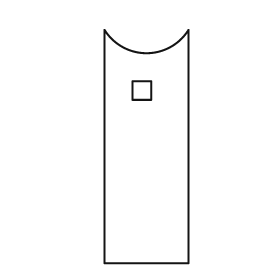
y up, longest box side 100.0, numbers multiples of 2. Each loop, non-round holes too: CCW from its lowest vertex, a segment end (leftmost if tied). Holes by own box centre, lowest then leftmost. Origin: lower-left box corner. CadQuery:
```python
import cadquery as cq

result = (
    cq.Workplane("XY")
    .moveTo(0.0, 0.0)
    .lineTo(36.0, 0.0)
    .lineTo(36.0, 100.0)
    .threePointArc((18.0, 90.0), (0.0, 100.0))
    .close()
    .moveTo(12.0, 70.0)
    .lineTo(20.0, 70.0)
    .lineTo(20.0, 78.0)
    .lineTo(12.0, 78.0)
    .close()
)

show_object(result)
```